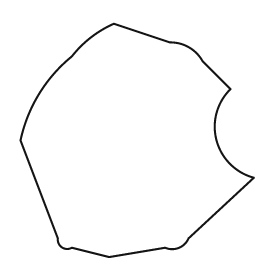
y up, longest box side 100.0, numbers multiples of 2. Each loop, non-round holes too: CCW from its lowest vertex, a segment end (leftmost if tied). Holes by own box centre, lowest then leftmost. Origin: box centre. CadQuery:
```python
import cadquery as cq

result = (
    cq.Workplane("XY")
    .moveTo(-12.0, -50.0)
    .lineTo(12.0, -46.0)
    .threePointArc((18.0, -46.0), (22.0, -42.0))
    .lineTo(50.0, -16.0)
    .threePointArc((34.0, 0.0), (40.0, 22.0))
    .lineTo(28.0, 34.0)
    .threePointArc((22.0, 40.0), (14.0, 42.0))
    .lineTo(-10.0, 50.0)
    .threePointArc((-20.0, 44.0), (-28.0, 36.0))
    .threePointArc((-42.0, 20.0), (-50.0, 0.0))
    .lineTo(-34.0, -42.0)
    .threePointArc((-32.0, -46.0), (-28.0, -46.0))
    .close()
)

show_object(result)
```